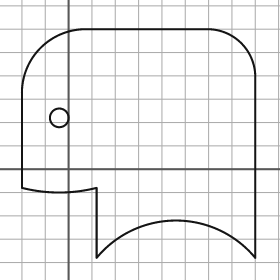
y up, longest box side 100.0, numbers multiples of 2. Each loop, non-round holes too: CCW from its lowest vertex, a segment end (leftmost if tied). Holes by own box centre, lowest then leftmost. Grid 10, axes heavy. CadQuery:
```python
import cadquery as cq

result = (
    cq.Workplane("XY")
    .moveTo(12.0, -38.0)
    .threePointArc((46.0, -22.0), (80.0, -38.0))
    .lineTo(80.0, 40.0)
    .threePointArc((74.0, 54.0), (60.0, 60.0))
    .lineTo(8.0, 60.0)
    .threePointArc((-12.0, 52.0), (-20.0, 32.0))
    .lineTo(-20.0, -8.0)
    .threePointArc((-4.0, -10.0), (12.0, -8.0))
    .close()
    .moveTo(-4.0, 22.0)
    .circle(4.0)
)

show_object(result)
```